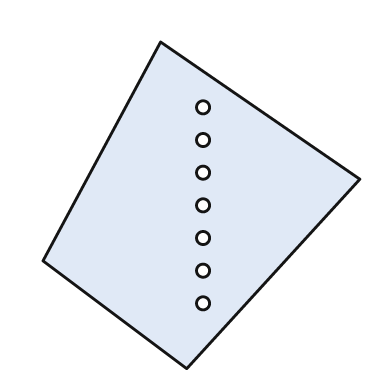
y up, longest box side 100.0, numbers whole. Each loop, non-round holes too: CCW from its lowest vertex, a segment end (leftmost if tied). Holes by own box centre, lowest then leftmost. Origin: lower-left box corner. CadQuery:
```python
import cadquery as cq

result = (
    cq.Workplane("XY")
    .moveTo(44.0, 0.0)
    .lineTo(97.0, 58.0)
    .lineTo(36.0, 100.0)
    .lineTo(0.0, 33.0)
    .close()
    .moveTo(49.0, 20.0)
    .circle(2.0)
    .moveTo(49.0, 30.0)
    .circle(2.0)
    .moveTo(49.0, 40.0)
    .circle(2.0)
    .moveTo(49.0, 50.0)
    .circle(2.0)
    .moveTo(49.0, 60.0)
    .circle(2.0)
    .moveTo(49.0, 70.0)
    .circle(2.0)
    .moveTo(49.0, 80.0)
    .circle(2.0)
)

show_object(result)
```